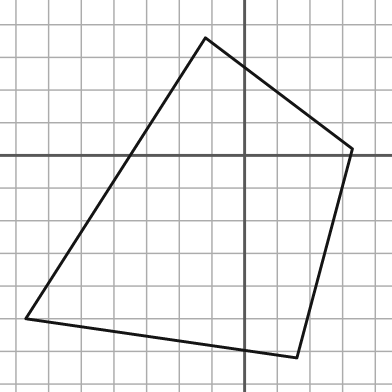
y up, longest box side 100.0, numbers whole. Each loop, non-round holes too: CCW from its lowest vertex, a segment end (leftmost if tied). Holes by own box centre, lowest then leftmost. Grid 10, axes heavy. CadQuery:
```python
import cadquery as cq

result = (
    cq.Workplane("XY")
    .moveTo(16.0, -62.0)
    .lineTo(33.0, 2.0)
    .lineTo(-12.0, 36.0)
    .lineTo(-67.0, -50.0)
    .close()
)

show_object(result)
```